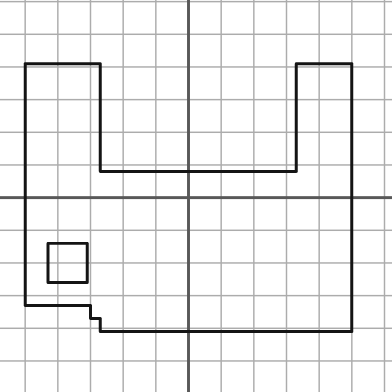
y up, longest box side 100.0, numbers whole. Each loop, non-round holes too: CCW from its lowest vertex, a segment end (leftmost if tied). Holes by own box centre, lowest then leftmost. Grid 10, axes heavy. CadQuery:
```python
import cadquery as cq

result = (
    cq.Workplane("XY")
    .moveTo(-27.0, -41.0)
    .lineTo(50.0, -41.0)
    .lineTo(50.0, 41.0)
    .lineTo(33.0, 41.0)
    .lineTo(33.0, 8.0)
    .lineTo(-27.0, 8.0)
    .lineTo(-27.0, 41.0)
    .lineTo(-50.0, 41.0)
    .lineTo(-50.0, -33.0)
    .lineTo(-30.0, -33.0)
    .lineTo(-30.0, -37.0)
    .lineTo(-27.0, -37.0)
    .close()
    .moveTo(-43.0, -26.0)
    .lineTo(-31.0, -26.0)
    .lineTo(-31.0, -14.0)
    .lineTo(-43.0, -14.0)
    .close()
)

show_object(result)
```